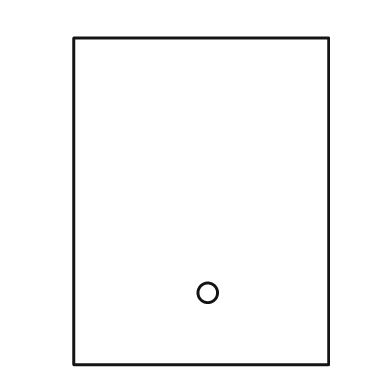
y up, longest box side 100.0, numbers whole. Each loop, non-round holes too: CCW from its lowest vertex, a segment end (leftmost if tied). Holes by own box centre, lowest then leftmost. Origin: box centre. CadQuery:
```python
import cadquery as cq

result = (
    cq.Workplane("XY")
    .moveTo(-39.0, -50.0)
    .lineTo(39.0, -50.0)
    .lineTo(39.0, 50.0)
    .lineTo(-39.0, 50.0)
    .close()
    .moveTo(2.0, -28.0)
    .circle(3.0)
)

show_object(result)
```